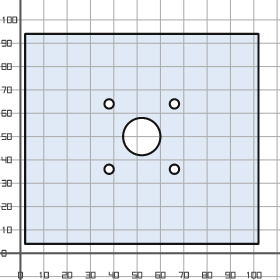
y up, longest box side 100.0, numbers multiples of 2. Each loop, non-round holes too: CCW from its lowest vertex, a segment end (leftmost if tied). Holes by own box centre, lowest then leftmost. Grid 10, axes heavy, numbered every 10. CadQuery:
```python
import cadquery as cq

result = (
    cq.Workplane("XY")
    .moveTo(2.0, 4.0)
    .lineTo(102.0, 4.0)
    .lineTo(102.0, 94.0)
    .lineTo(2.0, 94.0)
    .close()
    .moveTo(38.0, 36.0)
    .circle(2.0)
    .moveTo(66.0, 36.0)
    .circle(2.0)
    .moveTo(52.0, 50.0)
    .circle(8.0)
    .moveTo(38.0, 64.0)
    .circle(2.0)
    .moveTo(66.0, 64.0)
    .circle(2.0)
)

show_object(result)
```